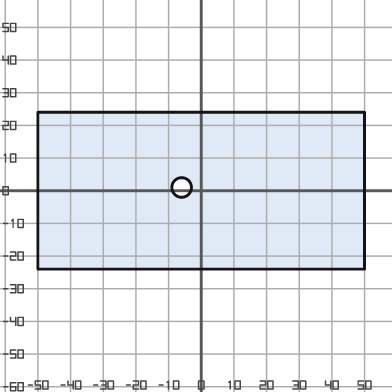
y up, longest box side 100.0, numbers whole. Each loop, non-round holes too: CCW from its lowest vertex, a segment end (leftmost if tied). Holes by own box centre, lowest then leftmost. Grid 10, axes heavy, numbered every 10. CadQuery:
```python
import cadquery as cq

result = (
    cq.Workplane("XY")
    .moveTo(-50.0, -24.0)
    .lineTo(50.0, -24.0)
    .lineTo(50.0, 24.0)
    .lineTo(-50.0, 24.0)
    .close()
    .moveTo(-6.0, 1.0)
    .circle(3.0)
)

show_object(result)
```